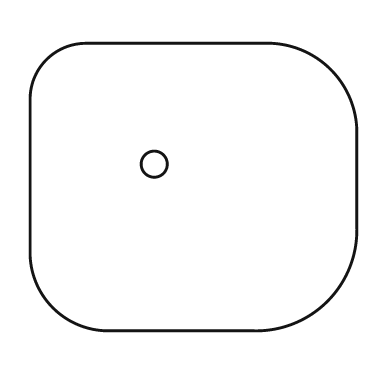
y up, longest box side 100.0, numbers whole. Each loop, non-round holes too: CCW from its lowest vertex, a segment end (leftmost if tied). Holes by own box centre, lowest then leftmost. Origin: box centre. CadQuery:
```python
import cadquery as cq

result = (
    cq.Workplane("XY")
    .moveTo(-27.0, -44.0)
    .lineTo(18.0, -44.0)
    .threePointArc((41.0, -35.0), (50.0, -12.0))
    .lineTo(50.0, 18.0)
    .threePointArc((42.0, 36.0), (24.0, 44.0))
    .lineTo(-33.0, 44.0)
    .threePointArc((-45.0, 39.0), (-50.0, 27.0))
    .lineTo(-50.0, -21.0)
    .threePointArc((-43.0, -37.0), (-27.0, -44.0))
    .close()
    .moveTo(-12.0, 7.0)
    .circle(4.0)
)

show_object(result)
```